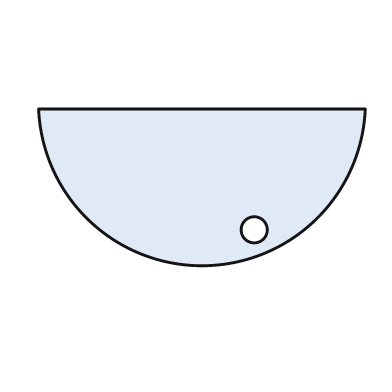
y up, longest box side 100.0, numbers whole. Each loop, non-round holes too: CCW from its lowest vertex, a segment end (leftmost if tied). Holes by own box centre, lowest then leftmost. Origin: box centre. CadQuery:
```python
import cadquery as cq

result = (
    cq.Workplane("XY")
    .moveTo(-50.0, 24.0)
    .threePointArc((0.0, -24.0), (50.0, 24.0))
    .close()
    .moveTo(16.0, -13.0)
    .circle(4.0)
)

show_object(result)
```